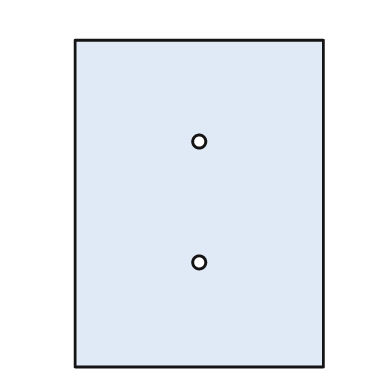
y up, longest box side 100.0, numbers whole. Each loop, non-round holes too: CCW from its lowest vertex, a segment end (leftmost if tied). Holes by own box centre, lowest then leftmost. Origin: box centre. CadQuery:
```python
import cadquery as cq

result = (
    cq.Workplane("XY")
    .moveTo(-38.0, -50.0)
    .lineTo(38.0, -50.0)
    .lineTo(38.0, 50.0)
    .lineTo(-38.0, 50.0)
    .close()
    .moveTo(0.0, -18.0)
    .circle(2.0)
    .moveTo(0.0, 19.0)
    .circle(2.0)
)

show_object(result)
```